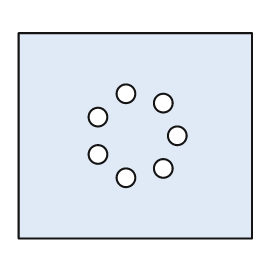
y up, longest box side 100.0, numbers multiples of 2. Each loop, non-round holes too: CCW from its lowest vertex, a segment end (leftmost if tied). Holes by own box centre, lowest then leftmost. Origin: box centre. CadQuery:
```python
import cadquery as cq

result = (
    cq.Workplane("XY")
    .moveTo(-50.0, -44.0)
    .lineTo(50.0, -44.0)
    .lineTo(50.0, 44.0)
    .lineTo(-50.0, 44.0)
    .close()
    .moveTo(-4.0, -18.0)
    .circle(4.0)
    .moveTo(12.0, -14.0)
    .circle(4.0)
    .moveTo(-16.0, -8.0)
    .circle(4.0)
    .moveTo(18.0, 0.0)
    .circle(4.0)
    .moveTo(-16.0, 8.0)
    .circle(4.0)
    .moveTo(12.0, 14.0)
    .circle(4.0)
    .moveTo(-4.0, 18.0)
    .circle(4.0)
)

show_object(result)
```